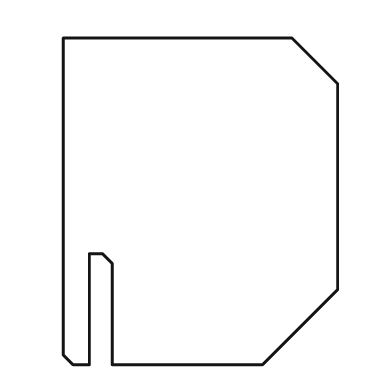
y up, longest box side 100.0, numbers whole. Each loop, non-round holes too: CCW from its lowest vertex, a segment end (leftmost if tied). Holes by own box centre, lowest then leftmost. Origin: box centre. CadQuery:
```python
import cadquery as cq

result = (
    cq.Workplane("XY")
    .moveTo(-39.0, -50.0)
    .lineTo(-34.0, -50.0)
    .lineTo(-34.0, -16.0)
    .lineTo(-30.0, -16.0)
    .lineTo(-27.0, -19.0)
    .lineTo(-27.0, -50.0)
    .lineTo(19.0, -50.0)
    .lineTo(42.0, -27.0)
    .lineTo(42.0, 36.0)
    .lineTo(28.0, 50.0)
    .lineTo(-42.0, 50.0)
    .lineTo(-42.0, -47.0)
    .close()
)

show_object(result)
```